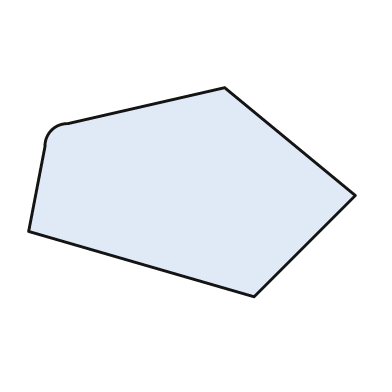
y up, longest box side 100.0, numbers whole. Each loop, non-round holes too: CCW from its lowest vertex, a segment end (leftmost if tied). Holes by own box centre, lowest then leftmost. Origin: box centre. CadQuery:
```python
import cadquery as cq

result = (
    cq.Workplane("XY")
    .moveTo(19.0, -32.0)
    .lineTo(50.0, -1.0)
    .lineTo(10.0, 32.0)
    .lineTo(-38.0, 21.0)
    .threePointArc((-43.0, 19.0), (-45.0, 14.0))
    .lineTo(-50.0, -12.0)
    .close()
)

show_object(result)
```